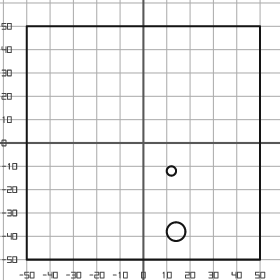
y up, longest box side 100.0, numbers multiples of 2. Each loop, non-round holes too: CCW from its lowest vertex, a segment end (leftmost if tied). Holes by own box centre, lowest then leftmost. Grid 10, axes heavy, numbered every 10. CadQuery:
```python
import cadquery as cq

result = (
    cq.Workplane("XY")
    .moveTo(-50.0, -50.0)
    .lineTo(50.0, -50.0)
    .lineTo(50.0, 50.0)
    .lineTo(-50.0, 50.0)
    .close()
    .moveTo(14.0, -38.0)
    .circle(4.0)
    .moveTo(12.0, -12.0)
    .circle(2.0)
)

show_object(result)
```